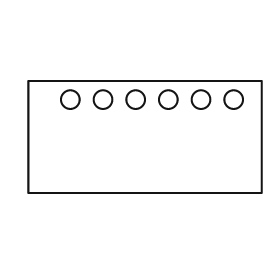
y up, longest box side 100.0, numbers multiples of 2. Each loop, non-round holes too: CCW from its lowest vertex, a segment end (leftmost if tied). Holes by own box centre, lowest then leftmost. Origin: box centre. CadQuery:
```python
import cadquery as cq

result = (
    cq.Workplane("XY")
    .moveTo(-50.0, -24.0)
    .lineTo(50.0, -24.0)
    .lineTo(50.0, 24.0)
    .lineTo(-50.0, 24.0)
    .close()
    .moveTo(-32.0, 16.0)
    .circle(4.0)
    .moveTo(-18.0, 16.0)
    .circle(4.0)
    .moveTo(-4.0, 16.0)
    .circle(4.0)
    .moveTo(10.0, 16.0)
    .circle(4.0)
    .moveTo(24.0, 16.0)
    .circle(4.0)
    .moveTo(38.0, 16.0)
    .circle(4.0)
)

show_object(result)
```